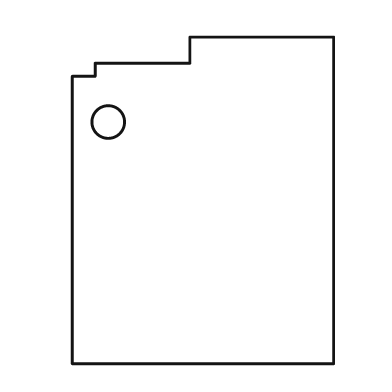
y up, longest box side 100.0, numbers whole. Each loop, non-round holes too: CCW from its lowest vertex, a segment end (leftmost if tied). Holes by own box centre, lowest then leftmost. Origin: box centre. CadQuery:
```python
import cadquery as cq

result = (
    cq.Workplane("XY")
    .moveTo(-40.0, -50.0)
    .lineTo(40.0, -50.0)
    .lineTo(40.0, 50.0)
    .lineTo(-4.0, 50.0)
    .lineTo(-4.0, 42.0)
    .lineTo(-33.0, 42.0)
    .lineTo(-33.0, 38.0)
    .lineTo(-40.0, 38.0)
    .close()
    .moveTo(-29.0, 24.0)
    .circle(5.0)
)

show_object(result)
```